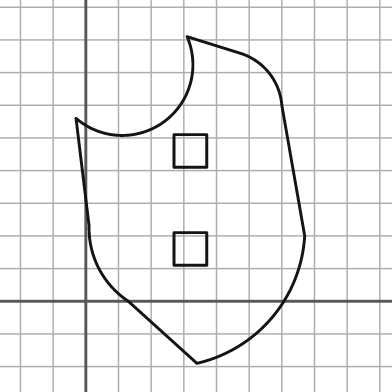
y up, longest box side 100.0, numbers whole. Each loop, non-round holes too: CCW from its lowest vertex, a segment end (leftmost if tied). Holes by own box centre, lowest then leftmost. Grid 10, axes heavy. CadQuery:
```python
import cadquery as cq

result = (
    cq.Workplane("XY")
    .moveTo(34.0, -19.0)
    .threePointArc((57.0, -5.0), (67.0, 20.0))
    .lineTo(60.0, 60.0)
    .threePointArc((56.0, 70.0), (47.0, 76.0))
    .lineTo(31.0, 81.0)
    .threePointArc((24.0, 55.0), (-3.0, 56.0))
    .lineTo(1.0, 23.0)
    .threePointArc((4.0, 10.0), (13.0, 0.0))
    .close()
    .moveTo(27.0, 11.0)
    .lineTo(37.0, 11.0)
    .lineTo(37.0, 21.0)
    .lineTo(27.0, 21.0)
    .close()
    .moveTo(27.0, 41.0)
    .lineTo(37.0, 41.0)
    .lineTo(37.0, 51.0)
    .lineTo(27.0, 51.0)
    .close()
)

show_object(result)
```